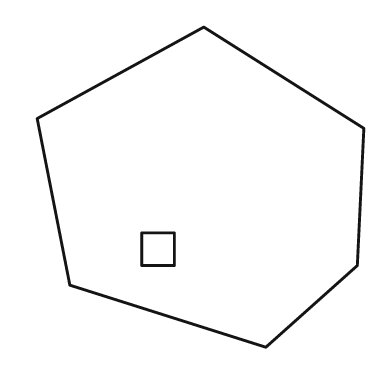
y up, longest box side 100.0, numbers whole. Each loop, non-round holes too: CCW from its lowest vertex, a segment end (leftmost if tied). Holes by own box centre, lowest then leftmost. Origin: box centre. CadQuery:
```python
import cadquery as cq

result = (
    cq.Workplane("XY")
    .moveTo(20.0, -49.0)
    .lineTo(48.0, -24.0)
    .lineTo(50.0, 18.0)
    .lineTo(1.0, 49.0)
    .lineTo(-50.0, 21.0)
    .lineTo(-40.0, -30.0)
    .close()
    .moveTo(-18.0, -24.0)
    .lineTo(-8.0, -24.0)
    .lineTo(-8.0, -14.0)
    .lineTo(-18.0, -14.0)
    .close()
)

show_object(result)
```